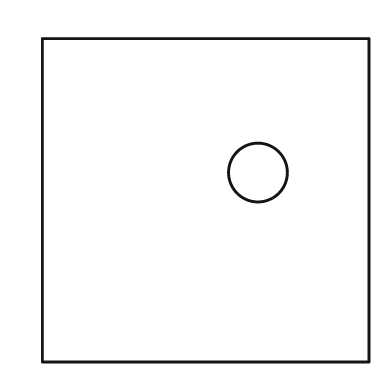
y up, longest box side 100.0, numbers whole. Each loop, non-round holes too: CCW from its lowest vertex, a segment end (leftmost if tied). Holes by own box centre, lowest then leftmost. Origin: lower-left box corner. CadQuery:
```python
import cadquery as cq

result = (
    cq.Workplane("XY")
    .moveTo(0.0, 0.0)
    .lineTo(100.0, 0.0)
    .lineTo(100.0, 99.0)
    .lineTo(0.0, 99.0)
    .close()
    .moveTo(66.0, 58.0)
    .circle(9.0)
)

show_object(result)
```